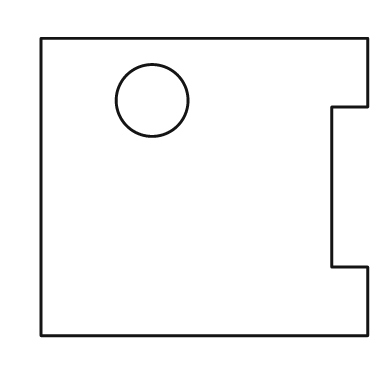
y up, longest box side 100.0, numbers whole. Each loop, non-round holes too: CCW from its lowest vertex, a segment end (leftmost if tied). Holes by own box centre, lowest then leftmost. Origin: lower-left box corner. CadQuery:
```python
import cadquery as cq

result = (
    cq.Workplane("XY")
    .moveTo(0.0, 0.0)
    .lineTo(100.0, 0.0)
    .lineTo(100.0, 21.0)
    .lineTo(89.0, 21.0)
    .lineTo(89.0, 70.0)
    .lineTo(100.0, 70.0)
    .lineTo(100.0, 91.0)
    .lineTo(0.0, 91.0)
    .close()
    .moveTo(34.0, 72.0)
    .circle(11.0)
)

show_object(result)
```